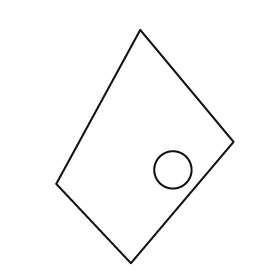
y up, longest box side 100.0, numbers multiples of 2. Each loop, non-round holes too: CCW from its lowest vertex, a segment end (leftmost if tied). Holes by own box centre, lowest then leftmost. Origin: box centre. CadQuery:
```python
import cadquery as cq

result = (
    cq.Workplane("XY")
    .moveTo(-6.0, -50.0)
    .lineTo(38.0, 2.0)
    .lineTo(-2.0, 50.0)
    .lineTo(-38.0, -16.0)
    .close()
    .moveTo(12.0, -10.0)
    .circle(8.0)
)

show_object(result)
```